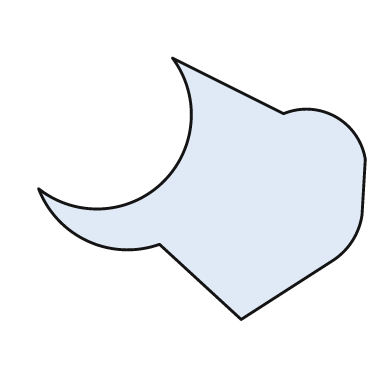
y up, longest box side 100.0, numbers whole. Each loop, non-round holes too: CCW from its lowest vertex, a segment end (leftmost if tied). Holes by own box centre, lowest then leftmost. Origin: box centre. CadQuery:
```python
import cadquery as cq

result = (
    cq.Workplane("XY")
    .moveTo(12.0, -40.0)
    .lineTo(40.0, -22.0)
    .threePointArc((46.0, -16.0), (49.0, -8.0))
    .lineTo(50.0, 9.0)
    .threePointArc((41.0, 22.0), (25.0, 23.0))
    .lineTo(-9.0, 40.0)
    .threePointArc((-12.0, 2.0), (-50.0, 0.0))
    .threePointArc((-35.0, -16.0), (-13.0, -17.0))
    .close()
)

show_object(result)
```